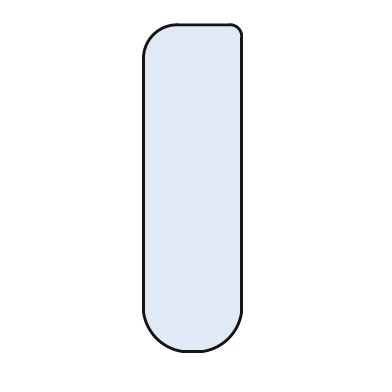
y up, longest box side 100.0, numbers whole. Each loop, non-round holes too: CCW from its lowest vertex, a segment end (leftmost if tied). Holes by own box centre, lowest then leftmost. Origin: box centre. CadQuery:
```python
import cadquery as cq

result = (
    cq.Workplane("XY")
    .moveTo(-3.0, -50.0)
    .lineTo(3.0, -50.0)
    .threePointArc((11.0, -46.0), (15.0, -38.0))
    .lineTo(15.0, 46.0)
    .threePointArc((14.0, 49.0), (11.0, 50.0))
    .lineTo(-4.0, 50.0)
    .threePointArc((-12.0, 47.0), (-15.0, 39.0))
    .lineTo(-15.0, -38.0)
    .threePointArc((-11.0, -46.0), (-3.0, -50.0))
    .close()
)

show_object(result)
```